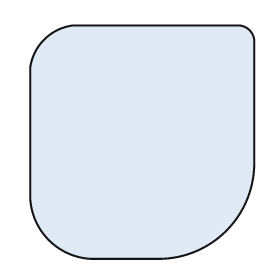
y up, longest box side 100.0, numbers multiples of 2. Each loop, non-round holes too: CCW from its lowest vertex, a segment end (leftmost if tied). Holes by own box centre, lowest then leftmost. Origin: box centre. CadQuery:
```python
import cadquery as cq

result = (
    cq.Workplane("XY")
    .moveTo(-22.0, -50.0)
    .lineTo(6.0, -50.0)
    .threePointArc((36.0, -38.0), (48.0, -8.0))
    .lineTo(48.0, 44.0)
    .threePointArc((46.0, 48.0), (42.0, 50.0))
    .lineTo(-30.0, 50.0)
    .threePointArc((-42.0, 44.0), (-48.0, 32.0))
    .lineTo(-48.0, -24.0)
    .threePointArc((-40.0, -42.0), (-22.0, -50.0))
    .close()
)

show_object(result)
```